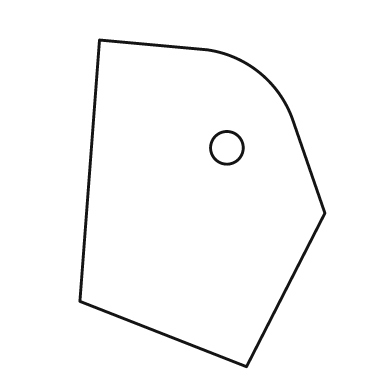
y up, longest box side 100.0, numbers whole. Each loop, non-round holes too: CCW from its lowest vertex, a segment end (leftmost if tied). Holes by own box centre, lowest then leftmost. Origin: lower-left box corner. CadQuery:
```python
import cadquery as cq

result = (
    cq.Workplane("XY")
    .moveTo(51.0, 0.0)
    .lineTo(75.0, 47.0)
    .lineTo(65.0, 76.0)
    .threePointArc((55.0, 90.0), (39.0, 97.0))
    .lineTo(6.0, 100.0)
    .lineTo(0.0, 20.0)
    .close()
    .moveTo(45.0, 67.0)
    .circle(5.0)
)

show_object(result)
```